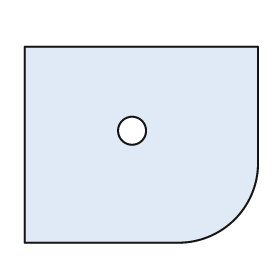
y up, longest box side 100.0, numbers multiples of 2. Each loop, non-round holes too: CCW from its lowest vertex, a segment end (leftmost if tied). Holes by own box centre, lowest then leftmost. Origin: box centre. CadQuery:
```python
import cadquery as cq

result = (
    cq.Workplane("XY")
    .moveTo(-50.0, -42.0)
    .lineTo(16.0, -42.0)
    .threePointArc((40.0, -32.0), (50.0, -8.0))
    .lineTo(50.0, 42.0)
    .lineTo(-50.0, 42.0)
    .close()
    .moveTo(-4.0, 6.0)
    .circle(6.0)
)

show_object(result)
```